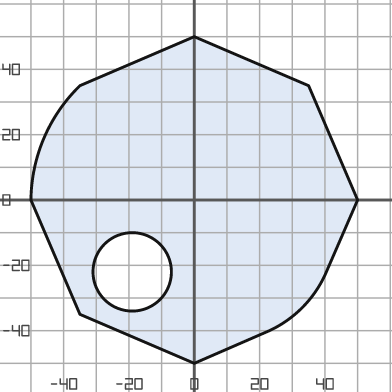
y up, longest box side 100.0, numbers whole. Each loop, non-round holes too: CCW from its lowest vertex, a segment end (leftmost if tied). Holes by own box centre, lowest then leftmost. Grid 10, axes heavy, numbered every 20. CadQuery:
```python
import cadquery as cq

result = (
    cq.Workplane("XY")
    .moveTo(0.0, -50.0)
    .lineTo(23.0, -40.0)
    .threePointArc((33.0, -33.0), (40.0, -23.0))
    .lineTo(50.0, 0.0)
    .lineTo(35.0, 35.0)
    .lineTo(0.0, 50.0)
    .lineTo(-35.0, 35.0)
    .threePointArc((-46.0, 19.0), (-50.0, 0.0))
    .lineTo(-35.0, -35.0)
    .close()
    .moveTo(-19.0, -22.0)
    .circle(12.0)
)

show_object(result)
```